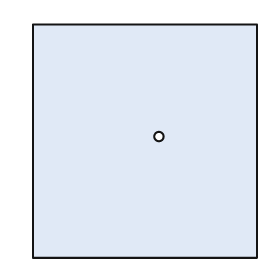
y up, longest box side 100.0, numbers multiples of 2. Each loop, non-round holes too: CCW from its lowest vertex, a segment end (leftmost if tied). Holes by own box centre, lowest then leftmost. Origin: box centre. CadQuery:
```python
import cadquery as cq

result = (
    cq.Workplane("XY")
    .moveTo(-48.0, -50.0)
    .lineTo(48.0, -50.0)
    .lineTo(48.0, 50.0)
    .lineTo(-48.0, 50.0)
    .close()
    .moveTo(6.0, 2.0)
    .circle(2.0)
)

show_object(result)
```